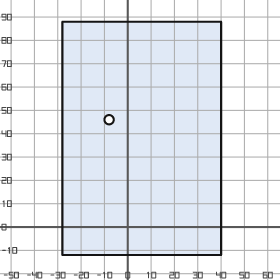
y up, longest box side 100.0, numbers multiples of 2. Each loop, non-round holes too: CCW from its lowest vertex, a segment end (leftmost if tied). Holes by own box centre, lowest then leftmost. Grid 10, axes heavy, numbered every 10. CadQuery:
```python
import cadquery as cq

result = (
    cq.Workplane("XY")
    .moveTo(-28.0, -12.0)
    .lineTo(40.0, -12.0)
    .lineTo(40.0, 88.0)
    .lineTo(-28.0, 88.0)
    .close()
    .moveTo(-8.0, 46.0)
    .circle(2.0)
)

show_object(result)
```